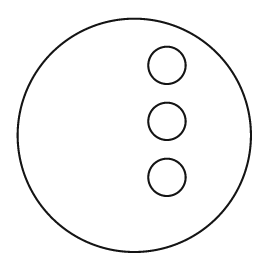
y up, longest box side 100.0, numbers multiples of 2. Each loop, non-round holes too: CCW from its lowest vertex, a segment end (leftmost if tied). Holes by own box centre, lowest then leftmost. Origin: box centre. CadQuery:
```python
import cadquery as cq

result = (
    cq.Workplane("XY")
    .moveTo(0.0, 0.0)
    .circle(50.0)
    .moveTo(14.0, -18.0)
    .circle(8.0)
    .moveTo(14.0, 6.0)
    .circle(8.0)
    .moveTo(14.0, 30.0)
    .circle(8.0)
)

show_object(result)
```